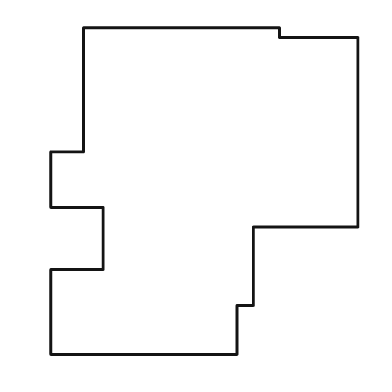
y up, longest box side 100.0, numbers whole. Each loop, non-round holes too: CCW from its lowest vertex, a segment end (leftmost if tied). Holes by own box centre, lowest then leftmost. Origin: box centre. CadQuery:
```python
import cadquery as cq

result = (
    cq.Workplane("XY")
    .moveTo(-47.0, -50.0)
    .lineTo(10.0, -50.0)
    .lineTo(10.0, -35.0)
    .lineTo(15.0, -35.0)
    .lineTo(15.0, -11.0)
    .lineTo(47.0, -11.0)
    .lineTo(47.0, 47.0)
    .lineTo(23.0, 47.0)
    .lineTo(23.0, 50.0)
    .lineTo(-37.0, 50.0)
    .lineTo(-37.0, 12.0)
    .lineTo(-47.0, 12.0)
    .lineTo(-47.0, -5.0)
    .lineTo(-31.0, -5.0)
    .lineTo(-31.0, -24.0)
    .lineTo(-47.0, -24.0)
    .close()
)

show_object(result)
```